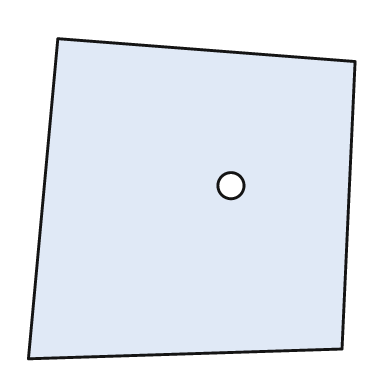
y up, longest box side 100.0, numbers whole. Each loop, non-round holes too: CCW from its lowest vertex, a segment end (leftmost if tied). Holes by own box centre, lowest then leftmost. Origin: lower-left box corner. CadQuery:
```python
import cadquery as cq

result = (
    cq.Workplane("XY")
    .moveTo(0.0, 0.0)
    .lineTo(96.0, 3.0)
    .lineTo(100.0, 91.0)
    .lineTo(9.0, 98.0)
    .close()
    .moveTo(62.0, 53.0)
    .circle(4.0)
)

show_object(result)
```